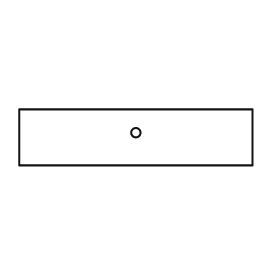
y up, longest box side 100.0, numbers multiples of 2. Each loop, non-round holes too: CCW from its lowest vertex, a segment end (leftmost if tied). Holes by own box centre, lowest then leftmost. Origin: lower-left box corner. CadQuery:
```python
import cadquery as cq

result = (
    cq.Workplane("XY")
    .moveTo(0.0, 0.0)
    .lineTo(100.0, 0.0)
    .lineTo(100.0, 24.0)
    .lineTo(0.0, 24.0)
    .close()
    .moveTo(50.0, 14.0)
    .circle(2.0)
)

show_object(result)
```